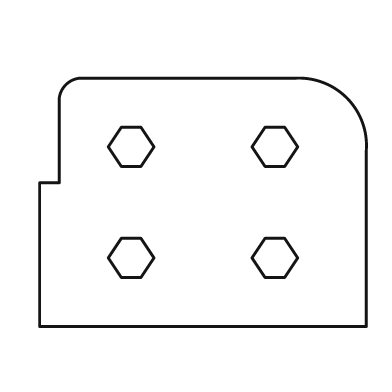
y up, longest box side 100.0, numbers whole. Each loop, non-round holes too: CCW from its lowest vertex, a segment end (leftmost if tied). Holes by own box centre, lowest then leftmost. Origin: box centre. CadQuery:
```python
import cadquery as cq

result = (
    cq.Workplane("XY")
    .moveTo(-50.0, -38.0)
    .lineTo(50.0, -38.0)
    .lineTo(50.0, 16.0)
    .threePointArc((44.0, 32.0), (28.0, 38.0))
    .lineTo(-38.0, 38.0)
    .threePointArc((-42.0, 36.0), (-44.0, 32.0))
    .lineTo(-44.0, 6.0)
    .lineTo(-50.0, 6.0)
    .close()
    .moveTo(-25.0, -23.0)
    .lineTo(-19.0, -23.0)
    .lineTo(-15.0, -17.0)
    .lineTo(-19.0, -11.0)
    .lineTo(-25.0, -11.0)
    .lineTo(-29.0, -17.0)
    .close()
    .moveTo(19.0, -23.0)
    .lineTo(25.0, -23.0)
    .lineTo(29.0, -17.0)
    .lineTo(25.0, -11.0)
    .lineTo(19.0, -11.0)
    .lineTo(15.0, -17.0)
    .close()
    .moveTo(-25.0, 11.0)
    .lineTo(-19.0, 11.0)
    .lineTo(-15.0, 17.0)
    .lineTo(-19.0, 23.0)
    .lineTo(-25.0, 23.0)
    .lineTo(-29.0, 17.0)
    .close()
    .moveTo(19.0, 11.0)
    .lineTo(25.0, 11.0)
    .lineTo(29.0, 17.0)
    .lineTo(25.0, 23.0)
    .lineTo(19.0, 23.0)
    .lineTo(15.0, 17.0)
    .close()
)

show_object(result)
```